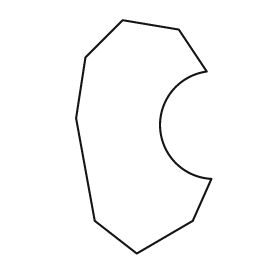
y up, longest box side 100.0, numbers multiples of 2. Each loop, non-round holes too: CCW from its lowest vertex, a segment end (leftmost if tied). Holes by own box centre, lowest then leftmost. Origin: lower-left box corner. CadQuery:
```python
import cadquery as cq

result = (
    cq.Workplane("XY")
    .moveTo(26.0, 0.0)
    .lineTo(50.0, 14.0)
    .lineTo(58.0, 32.0)
    .threePointArc((36.0, 54.0), (56.0, 78.0))
    .lineTo(44.0, 96.0)
    .lineTo(20.0, 100.0)
    .lineTo(4.0, 84.0)
    .lineTo(0.0, 58.0)
    .lineTo(8.0, 14.0)
    .close()
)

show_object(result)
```